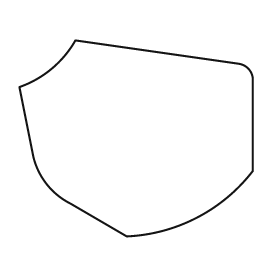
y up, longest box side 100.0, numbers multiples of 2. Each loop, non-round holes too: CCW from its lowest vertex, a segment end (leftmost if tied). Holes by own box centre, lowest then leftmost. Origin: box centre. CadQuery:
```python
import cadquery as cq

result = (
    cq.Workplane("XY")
    .moveTo(-4.0, -42.0)
    .threePointArc((26.0, -34.0), (50.0, -14.0))
    .lineTo(50.0, 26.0)
    .threePointArc((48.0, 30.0), (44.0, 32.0))
    .lineTo(-26.0, 42.0)
    .threePointArc((-36.0, 30.0), (-50.0, 22.0))
    .lineTo(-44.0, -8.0)
    .threePointArc((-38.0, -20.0), (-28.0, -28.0))
    .close()
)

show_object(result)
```